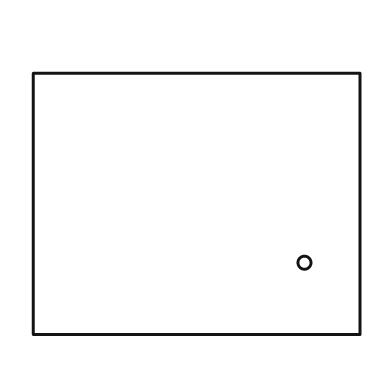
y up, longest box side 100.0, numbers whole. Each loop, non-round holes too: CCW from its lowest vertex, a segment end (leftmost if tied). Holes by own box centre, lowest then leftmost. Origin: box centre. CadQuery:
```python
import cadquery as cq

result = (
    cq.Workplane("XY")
    .moveTo(-50.0, -40.0)
    .lineTo(50.0, -40.0)
    .lineTo(50.0, 40.0)
    .lineTo(-50.0, 40.0)
    .close()
    .moveTo(33.0, -18.0)
    .circle(2.0)
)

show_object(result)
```